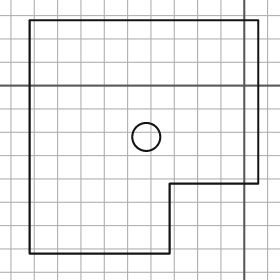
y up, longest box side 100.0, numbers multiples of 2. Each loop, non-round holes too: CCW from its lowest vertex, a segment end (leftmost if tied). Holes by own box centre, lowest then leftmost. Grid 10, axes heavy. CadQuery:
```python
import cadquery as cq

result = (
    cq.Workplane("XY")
    .moveTo(-92.0, -72.0)
    .lineTo(-32.0, -72.0)
    .lineTo(-32.0, -42.0)
    .lineTo(6.0, -42.0)
    .lineTo(6.0, 28.0)
    .lineTo(-92.0, 28.0)
    .close()
    .moveTo(-42.0, -22.0)
    .circle(6.0)
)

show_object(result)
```